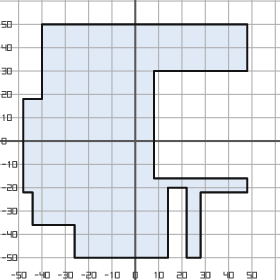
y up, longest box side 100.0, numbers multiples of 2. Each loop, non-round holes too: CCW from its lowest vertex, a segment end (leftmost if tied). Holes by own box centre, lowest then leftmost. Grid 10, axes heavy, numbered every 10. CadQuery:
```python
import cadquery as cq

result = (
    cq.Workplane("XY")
    .moveTo(-26.0, -50.0)
    .lineTo(14.0, -50.0)
    .lineTo(14.0, -20.0)
    .lineTo(22.0, -20.0)
    .lineTo(22.0, -50.0)
    .lineTo(28.0, -50.0)
    .lineTo(28.0, -22.0)
    .lineTo(48.0, -22.0)
    .lineTo(48.0, -16.0)
    .lineTo(8.0, -16.0)
    .lineTo(8.0, 30.0)
    .lineTo(48.0, 30.0)
    .lineTo(48.0, 50.0)
    .lineTo(-40.0, 50.0)
    .lineTo(-40.0, 18.0)
    .lineTo(-48.0, 18.0)
    .lineTo(-48.0, -22.0)
    .lineTo(-44.0, -22.0)
    .lineTo(-44.0, -36.0)
    .lineTo(-26.0, -36.0)
    .close()
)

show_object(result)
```